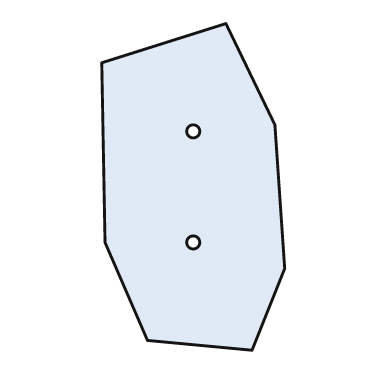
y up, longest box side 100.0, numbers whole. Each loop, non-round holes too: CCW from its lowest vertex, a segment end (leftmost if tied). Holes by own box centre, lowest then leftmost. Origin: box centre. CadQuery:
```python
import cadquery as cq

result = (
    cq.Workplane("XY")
    .moveTo(18.0, -50.0)
    .lineTo(28.0, -25.0)
    .lineTo(25.0, 19.0)
    .lineTo(10.0, 50.0)
    .lineTo(-28.0, 38.0)
    .lineTo(-27.0, -17.0)
    .lineTo(-14.0, -47.0)
    .close()
    .moveTo(0.0, -17.0)
    .circle(2.0)
    .moveTo(0.0, 17.0)
    .circle(2.0)
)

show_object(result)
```